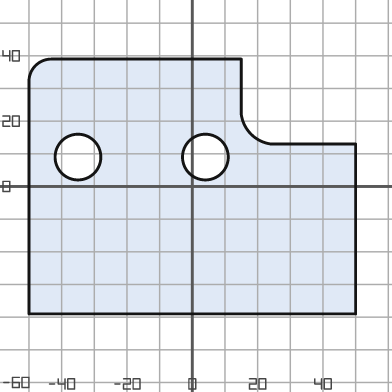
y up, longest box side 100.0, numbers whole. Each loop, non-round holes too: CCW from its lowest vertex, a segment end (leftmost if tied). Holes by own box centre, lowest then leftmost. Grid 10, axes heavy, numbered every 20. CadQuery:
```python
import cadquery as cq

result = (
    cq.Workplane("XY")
    .moveTo(-50.0, -39.0)
    .lineTo(50.0, -39.0)
    .lineTo(50.0, 13.0)
    .lineTo(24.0, 13.0)
    .threePointArc((18.0, 16.0), (15.0, 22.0))
    .lineTo(15.0, 39.0)
    .lineTo(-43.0, 39.0)
    .threePointArc((-48.0, 37.0), (-50.0, 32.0))
    .close()
    .moveTo(-35.0, 9.0)
    .circle(7.0)
    .moveTo(4.0, 9.0)
    .circle(7.0)
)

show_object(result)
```